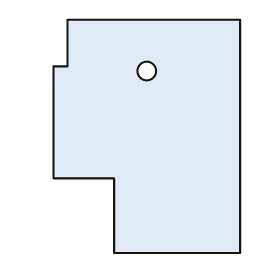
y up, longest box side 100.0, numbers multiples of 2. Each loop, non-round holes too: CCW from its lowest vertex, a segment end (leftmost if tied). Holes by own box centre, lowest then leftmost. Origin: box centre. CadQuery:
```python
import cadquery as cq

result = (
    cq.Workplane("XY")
    .moveTo(-14.0, -50.0)
    .lineTo(40.0, -50.0)
    .lineTo(40.0, 50.0)
    .lineTo(-34.0, 50.0)
    .lineTo(-34.0, 30.0)
    .lineTo(-40.0, 30.0)
    .lineTo(-40.0, -18.0)
    .lineTo(-14.0, -18.0)
    .close()
    .moveTo(0.0, 28.0)
    .circle(4.0)
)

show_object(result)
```